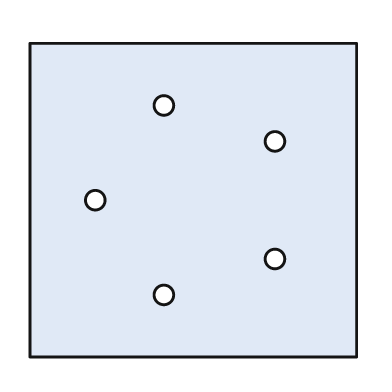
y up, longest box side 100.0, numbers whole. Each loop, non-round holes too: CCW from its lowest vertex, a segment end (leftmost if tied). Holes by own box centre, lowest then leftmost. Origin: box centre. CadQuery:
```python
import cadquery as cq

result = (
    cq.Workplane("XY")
    .moveTo(-50.0, -48.0)
    .lineTo(50.0, -48.0)
    .lineTo(50.0, 48.0)
    .lineTo(-50.0, 48.0)
    .close()
    .moveTo(-9.0, -29.0)
    .circle(3.0)
    .moveTo(25.0, -18.0)
    .circle(3.0)
    .moveTo(-30.0, 0.0)
    .circle(3.0)
    .moveTo(25.0, 18.0)
    .circle(3.0)
    .moveTo(-9.0, 29.0)
    .circle(3.0)
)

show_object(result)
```